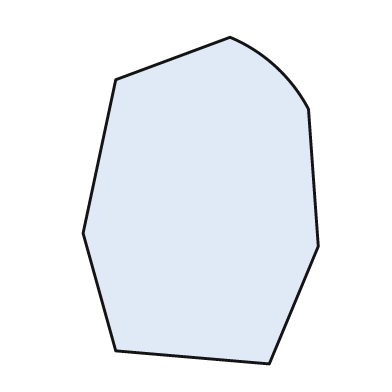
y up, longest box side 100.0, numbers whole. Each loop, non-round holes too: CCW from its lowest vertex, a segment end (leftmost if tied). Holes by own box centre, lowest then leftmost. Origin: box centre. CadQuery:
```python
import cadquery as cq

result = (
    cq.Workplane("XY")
    .moveTo(21.0, -50.0)
    .lineTo(36.0, -14.0)
    .lineTo(33.0, 28.0)
    .threePointArc((23.0, 41.0), (9.0, 50.0))
    .lineTo(-26.0, 37.0)
    .lineTo(-36.0, -10.0)
    .lineTo(-26.0, -46.0)
    .close()
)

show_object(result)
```